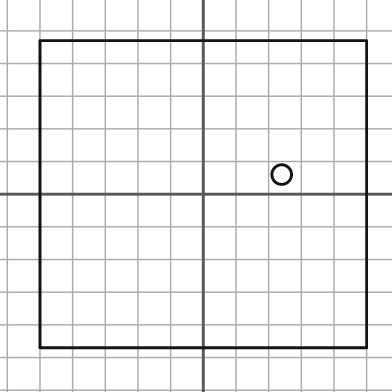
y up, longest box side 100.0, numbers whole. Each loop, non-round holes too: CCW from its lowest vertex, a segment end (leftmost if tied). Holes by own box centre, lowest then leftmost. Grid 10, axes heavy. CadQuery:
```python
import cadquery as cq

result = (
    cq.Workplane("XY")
    .moveTo(-50.0, -47.0)
    .lineTo(50.0, -47.0)
    .lineTo(50.0, 47.0)
    .lineTo(-50.0, 47.0)
    .close()
    .moveTo(24.0, 6.0)
    .circle(3.0)
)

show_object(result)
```